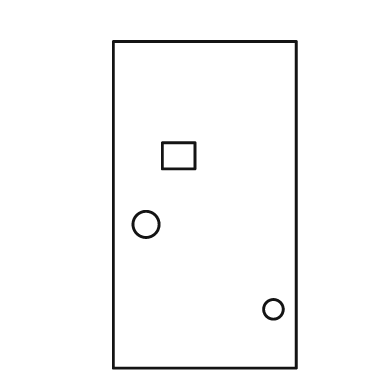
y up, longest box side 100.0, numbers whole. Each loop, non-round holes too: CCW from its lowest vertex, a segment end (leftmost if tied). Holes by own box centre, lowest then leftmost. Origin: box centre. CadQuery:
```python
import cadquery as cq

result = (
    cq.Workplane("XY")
    .moveTo(-28.0, -50.0)
    .lineTo(28.0, -50.0)
    .lineTo(28.0, 50.0)
    .lineTo(-28.0, 50.0)
    .close()
    .moveTo(21.0, -32.0)
    .circle(3.0)
    .moveTo(-18.0, -6.0)
    .circle(4.0)
    .moveTo(-13.0, 11.0)
    .lineTo(-3.0, 11.0)
    .lineTo(-3.0, 19.0)
    .lineTo(-13.0, 19.0)
    .close()
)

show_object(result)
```